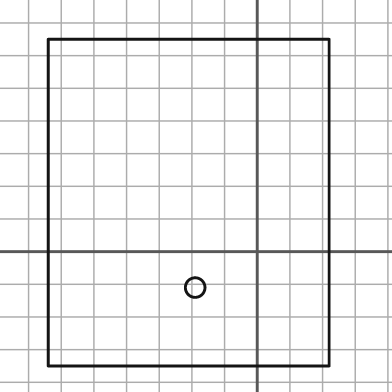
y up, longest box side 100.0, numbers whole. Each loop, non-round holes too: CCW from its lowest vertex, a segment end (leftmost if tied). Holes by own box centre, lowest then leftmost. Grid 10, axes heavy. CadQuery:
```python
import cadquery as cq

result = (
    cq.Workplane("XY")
    .moveTo(-64.0, -35.0)
    .lineTo(22.0, -35.0)
    .lineTo(22.0, 65.0)
    .lineTo(-64.0, 65.0)
    .close()
    .moveTo(-19.0, -11.0)
    .circle(3.0)
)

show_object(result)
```